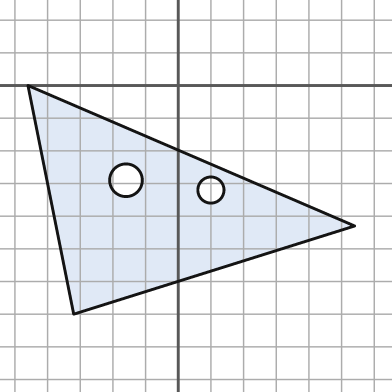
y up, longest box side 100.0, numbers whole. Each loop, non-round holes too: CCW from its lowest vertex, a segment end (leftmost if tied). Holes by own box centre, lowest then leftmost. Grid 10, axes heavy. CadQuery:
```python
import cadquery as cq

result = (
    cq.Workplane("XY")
    .moveTo(-32.0, -70.0)
    .lineTo(54.0, -43.0)
    .lineTo(-46.0, 0.0)
    .close()
    .moveTo(10.0, -32.0)
    .circle(4.0)
    .moveTo(-16.0, -29.0)
    .circle(5.0)
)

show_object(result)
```